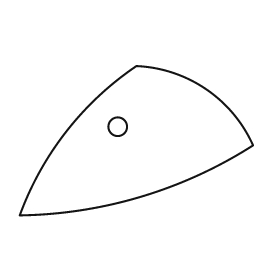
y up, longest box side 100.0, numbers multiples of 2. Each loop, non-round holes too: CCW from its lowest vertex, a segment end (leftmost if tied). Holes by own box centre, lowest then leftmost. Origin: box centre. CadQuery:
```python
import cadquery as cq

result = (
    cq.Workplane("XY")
    .moveTo(-50.0, -32.0)
    .threePointArc((2.0, -24.0), (50.0, -2.0))
    .threePointArc((30.0, 22.0), (0.0, 32.0))
    .threePointArc((-30.0, 4.0), (-50.0, -32.0))
    .close()
    .moveTo(-8.0, 6.0)
    .circle(4.0)
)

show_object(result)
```